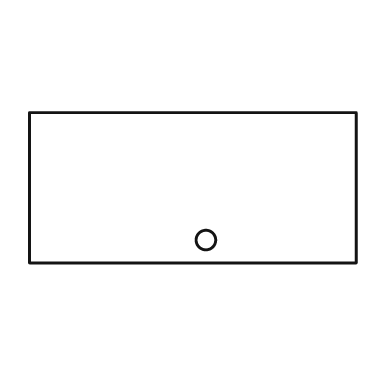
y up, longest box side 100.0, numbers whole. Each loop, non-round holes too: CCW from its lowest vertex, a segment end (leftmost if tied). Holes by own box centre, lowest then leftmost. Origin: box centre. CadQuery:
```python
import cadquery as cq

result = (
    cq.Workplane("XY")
    .moveTo(-50.0, -23.0)
    .lineTo(50.0, -23.0)
    .lineTo(50.0, 23.0)
    .lineTo(-50.0, 23.0)
    .close()
    .moveTo(4.0, -16.0)
    .circle(3.0)
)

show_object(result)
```